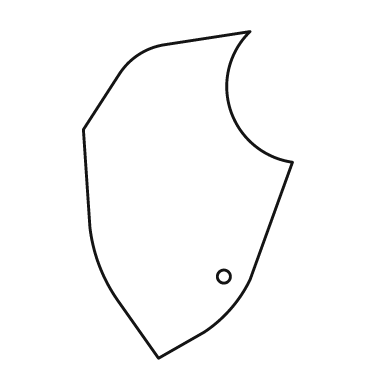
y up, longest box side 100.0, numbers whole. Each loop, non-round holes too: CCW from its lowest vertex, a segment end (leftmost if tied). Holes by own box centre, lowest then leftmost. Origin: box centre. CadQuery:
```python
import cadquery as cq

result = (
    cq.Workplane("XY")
    .moveTo(-9.0, -50.0)
    .lineTo(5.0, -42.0)
    .threePointArc((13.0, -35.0), (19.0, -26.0))
    .lineTo(32.0, 10.0)
    .threePointArc((13.0, 26.0), (19.0, 50.0))
    .lineTo(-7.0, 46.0)
    .threePointArc((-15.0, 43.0), (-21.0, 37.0))
    .lineTo(-32.0, 20.0)
    .lineTo(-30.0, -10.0)
    .threePointArc((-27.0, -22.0), (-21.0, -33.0))
    .close()
    .moveTo(11.0, -25.0)
    .circle(2.0)
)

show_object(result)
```